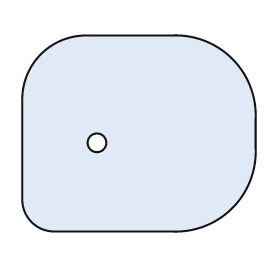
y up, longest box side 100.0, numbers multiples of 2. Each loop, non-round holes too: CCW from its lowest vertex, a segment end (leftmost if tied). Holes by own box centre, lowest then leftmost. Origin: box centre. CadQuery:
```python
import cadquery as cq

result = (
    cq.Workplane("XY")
    .moveTo(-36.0, -42.0)
    .lineTo(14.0, -42.0)
    .threePointArc((40.0, -32.0), (50.0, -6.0))
    .lineTo(50.0, 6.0)
    .threePointArc((40.0, 32.0), (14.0, 42.0))
    .lineTo(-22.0, 42.0)
    .threePointArc((-42.0, 34.0), (-50.0, 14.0))
    .lineTo(-50.0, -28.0)
    .threePointArc((-46.0, -38.0), (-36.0, -42.0))
    .close()
    .moveTo(-18.0, -4.0)
    .circle(4.0)
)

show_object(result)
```